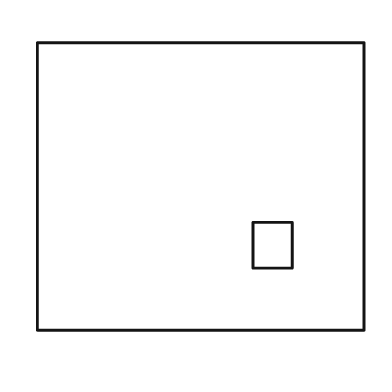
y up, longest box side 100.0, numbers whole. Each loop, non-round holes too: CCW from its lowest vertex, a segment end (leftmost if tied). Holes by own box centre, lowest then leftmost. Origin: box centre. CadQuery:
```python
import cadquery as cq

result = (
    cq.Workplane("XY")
    .moveTo(-50.0, -44.0)
    .lineTo(50.0, -44.0)
    .lineTo(50.0, 44.0)
    .lineTo(-50.0, 44.0)
    .close()
    .moveTo(16.0, -25.0)
    .lineTo(28.0, -25.0)
    .lineTo(28.0, -11.0)
    .lineTo(16.0, -11.0)
    .close()
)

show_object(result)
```